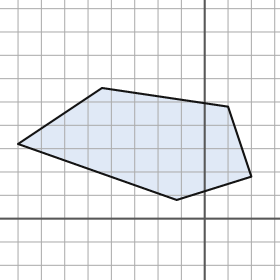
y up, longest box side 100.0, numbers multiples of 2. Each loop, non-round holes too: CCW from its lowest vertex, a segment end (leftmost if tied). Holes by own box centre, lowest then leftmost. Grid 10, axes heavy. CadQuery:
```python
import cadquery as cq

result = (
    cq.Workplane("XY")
    .moveTo(-12.0, 8.0)
    .lineTo(20.0, 18.0)
    .lineTo(10.0, 48.0)
    .lineTo(-44.0, 56.0)
    .lineTo(-80.0, 32.0)
    .close()
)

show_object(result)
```